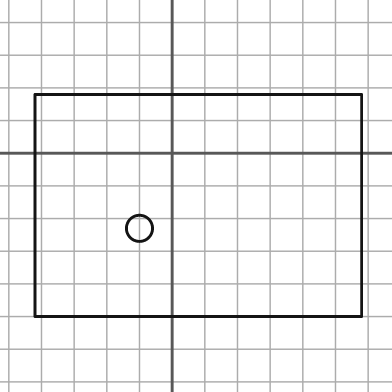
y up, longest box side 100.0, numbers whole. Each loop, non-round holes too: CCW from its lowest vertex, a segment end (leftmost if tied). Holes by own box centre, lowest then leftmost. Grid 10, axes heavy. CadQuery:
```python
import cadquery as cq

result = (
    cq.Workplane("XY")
    .moveTo(-42.0, -50.0)
    .lineTo(58.0, -50.0)
    .lineTo(58.0, 18.0)
    .lineTo(-42.0, 18.0)
    .close()
    .moveTo(-10.0, -23.0)
    .circle(4.0)
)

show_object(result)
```